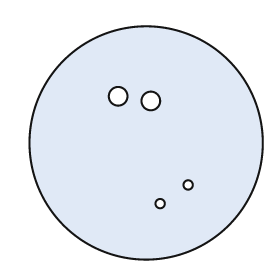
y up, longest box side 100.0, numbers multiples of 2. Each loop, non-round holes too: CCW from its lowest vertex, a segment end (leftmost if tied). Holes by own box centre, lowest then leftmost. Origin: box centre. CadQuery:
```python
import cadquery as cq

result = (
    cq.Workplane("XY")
    .moveTo(0.0, 0.0)
    .circle(50.0)
    .moveTo(6.0, -26.0)
    .circle(2.0)
    .moveTo(18.0, -18.0)
    .circle(2.0)
    .moveTo(2.0, 18.0)
    .circle(4.0)
    .moveTo(-12.0, 20.0)
    .circle(4.0)
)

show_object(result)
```